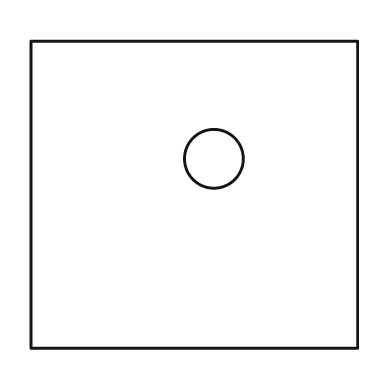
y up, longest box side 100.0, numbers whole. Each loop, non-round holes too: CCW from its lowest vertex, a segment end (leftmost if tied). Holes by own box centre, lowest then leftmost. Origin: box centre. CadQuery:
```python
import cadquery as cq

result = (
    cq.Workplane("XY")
    .moveTo(-50.0, -47.0)
    .lineTo(50.0, -47.0)
    .lineTo(50.0, 47.0)
    .lineTo(-50.0, 47.0)
    .close()
    .moveTo(6.0, 11.0)
    .circle(9.0)
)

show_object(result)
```